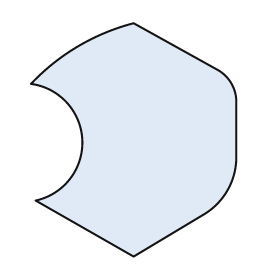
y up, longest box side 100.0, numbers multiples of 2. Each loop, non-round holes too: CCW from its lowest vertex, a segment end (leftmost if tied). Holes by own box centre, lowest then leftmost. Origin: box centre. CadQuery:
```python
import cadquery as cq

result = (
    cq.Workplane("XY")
    .moveTo(0.0, -50.0)
    .lineTo(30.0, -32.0)
    .threePointArc((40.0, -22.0), (44.0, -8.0))
    .lineTo(44.0, 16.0)
    .threePointArc((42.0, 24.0), (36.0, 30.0))
    .lineTo(0.0, 50.0)
    .threePointArc((-24.0, 40.0), (-44.0, 24.0))
    .threePointArc((-22.0, 0.0), (-42.0, -26.0))
    .close()
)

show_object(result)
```